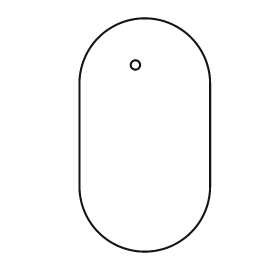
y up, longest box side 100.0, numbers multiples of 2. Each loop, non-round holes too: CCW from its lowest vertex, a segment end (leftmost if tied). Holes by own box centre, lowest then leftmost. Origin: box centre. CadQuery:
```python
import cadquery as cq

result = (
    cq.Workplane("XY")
    .moveTo(-28.0, -22.0)
    .threePointArc((0.0, -50.0), (28.0, -22.0))
    .lineTo(28.0, 22.0)
    .threePointArc((0.0, 50.0), (-28.0, 22.0))
    .close()
    .moveTo(-4.0, 30.0)
    .circle(2.0)
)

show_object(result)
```